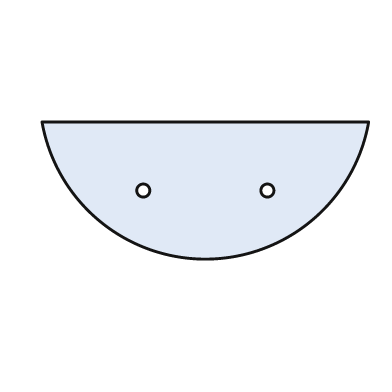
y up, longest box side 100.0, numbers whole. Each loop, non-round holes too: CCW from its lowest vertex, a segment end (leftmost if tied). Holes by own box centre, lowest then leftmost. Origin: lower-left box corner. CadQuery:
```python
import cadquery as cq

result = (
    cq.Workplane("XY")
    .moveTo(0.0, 42.0)
    .threePointArc((50.0, 0.0), (100.0, 42.0))
    .close()
    .moveTo(31.0, 21.0)
    .circle(2.0)
    .moveTo(69.0, 21.0)
    .circle(2.0)
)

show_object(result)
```